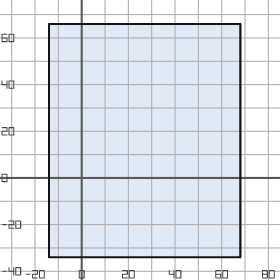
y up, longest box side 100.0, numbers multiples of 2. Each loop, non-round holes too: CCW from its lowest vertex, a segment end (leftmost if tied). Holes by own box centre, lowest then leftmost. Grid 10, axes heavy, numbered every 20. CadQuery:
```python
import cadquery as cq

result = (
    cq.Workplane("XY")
    .moveTo(-14.0, -34.0)
    .lineTo(68.0, -34.0)
    .lineTo(68.0, 66.0)
    .lineTo(-14.0, 66.0)
    .close()
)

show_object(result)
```